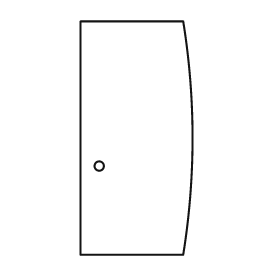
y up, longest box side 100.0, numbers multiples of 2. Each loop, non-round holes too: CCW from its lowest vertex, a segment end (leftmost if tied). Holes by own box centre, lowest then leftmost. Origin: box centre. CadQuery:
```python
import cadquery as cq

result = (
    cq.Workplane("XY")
    .moveTo(-24.0, -50.0)
    .lineTo(20.0, -50.0)
    .threePointArc((24.0, 0.0), (20.0, 50.0))
    .lineTo(-24.0, 50.0)
    .close()
    .moveTo(-16.0, -12.0)
    .circle(2.0)
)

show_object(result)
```